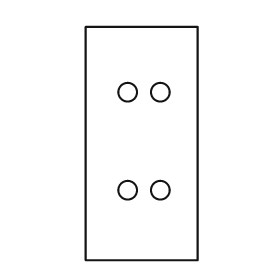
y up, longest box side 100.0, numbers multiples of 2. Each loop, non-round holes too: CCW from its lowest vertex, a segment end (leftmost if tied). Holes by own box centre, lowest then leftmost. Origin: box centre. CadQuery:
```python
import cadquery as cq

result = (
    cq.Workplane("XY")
    .moveTo(-24.0, -50.0)
    .lineTo(24.0, -50.0)
    .lineTo(24.0, 50.0)
    .lineTo(-24.0, 50.0)
    .close()
    .moveTo(-6.0, -20.0)
    .circle(4.0)
    .moveTo(8.0, -20.0)
    .circle(4.0)
    .moveTo(-6.0, 22.0)
    .circle(4.0)
    .moveTo(8.0, 22.0)
    .circle(4.0)
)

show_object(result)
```